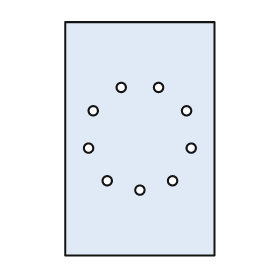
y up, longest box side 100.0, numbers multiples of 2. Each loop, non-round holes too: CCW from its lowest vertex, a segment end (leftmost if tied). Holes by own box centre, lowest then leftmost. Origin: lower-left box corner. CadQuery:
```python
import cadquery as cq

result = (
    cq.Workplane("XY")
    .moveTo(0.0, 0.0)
    .lineTo(64.0, 0.0)
    .lineTo(64.0, 100.0)
    .lineTo(0.0, 100.0)
    .close()
    .moveTo(32.0, 28.0)
    .circle(2.0)
    .moveTo(18.0, 32.0)
    .circle(2.0)
    .moveTo(46.0, 32.0)
    .circle(2.0)
    .moveTo(10.0, 46.0)
    .circle(2.0)
    .moveTo(54.0, 46.0)
    .circle(2.0)
    .moveTo(12.0, 62.0)
    .circle(2.0)
    .moveTo(52.0, 62.0)
    .circle(2.0)
    .moveTo(24.0, 72.0)
    .circle(2.0)
    .moveTo(40.0, 72.0)
    .circle(2.0)
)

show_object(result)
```